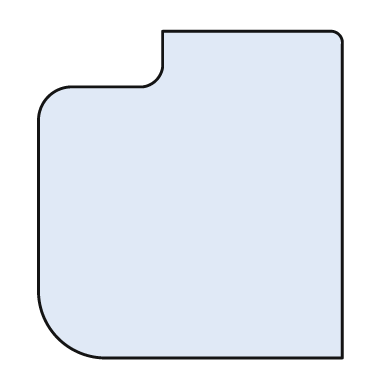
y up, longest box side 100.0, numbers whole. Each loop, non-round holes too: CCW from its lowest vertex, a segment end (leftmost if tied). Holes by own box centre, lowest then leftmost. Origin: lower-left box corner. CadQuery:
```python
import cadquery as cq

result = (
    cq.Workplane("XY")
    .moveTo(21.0, 0.0)
    .lineTo(93.0, 0.0)
    .lineTo(93.0, 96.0)
    .threePointArc((92.0, 99.0), (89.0, 100.0))
    .lineTo(38.0, 100.0)
    .lineTo(38.0, 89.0)
    .threePointArc((36.0, 85.0), (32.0, 83.0))
    .lineTo(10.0, 83.0)
    .threePointArc((3.0, 80.0), (0.0, 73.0))
    .lineTo(0.0, 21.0)
    .threePointArc((6.0, 6.0), (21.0, 0.0))
    .close()
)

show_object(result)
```